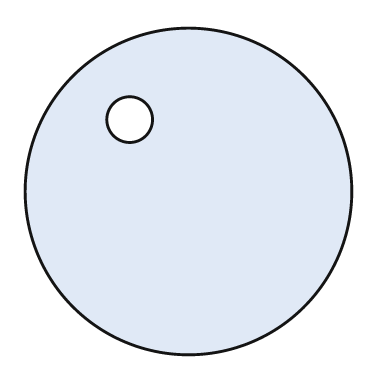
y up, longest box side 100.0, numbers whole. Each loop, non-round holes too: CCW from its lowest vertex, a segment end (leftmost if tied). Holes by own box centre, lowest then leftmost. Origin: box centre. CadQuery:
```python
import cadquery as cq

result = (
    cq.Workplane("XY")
    .moveTo(0.0, 0.0)
    .circle(50.0)
    .moveTo(-18.0, 22.0)
    .circle(7.0)
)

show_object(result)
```